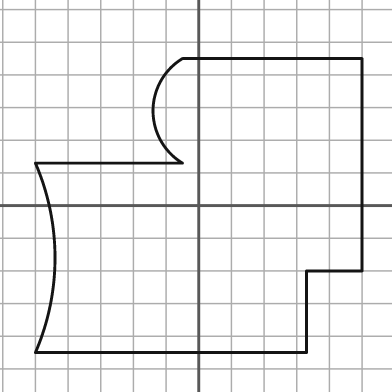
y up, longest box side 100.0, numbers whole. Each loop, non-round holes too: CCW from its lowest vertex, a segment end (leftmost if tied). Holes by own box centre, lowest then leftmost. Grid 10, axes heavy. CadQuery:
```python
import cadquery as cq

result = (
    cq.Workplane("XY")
    .moveTo(-50.0, -45.0)
    .lineTo(33.0, -45.0)
    .lineTo(33.0, -20.0)
    .lineTo(50.0, -20.0)
    .lineTo(50.0, 45.0)
    .lineTo(-5.0, 45.0)
    .threePointArc((-14.0, 29.0), (-5.0, 13.0))
    .lineTo(-50.0, 13.0)
    .threePointArc((-44.0, -16.0), (-50.0, -45.0))
    .close()
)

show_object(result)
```